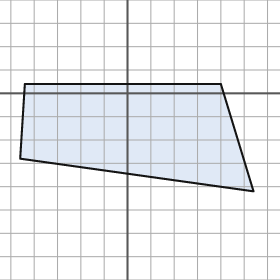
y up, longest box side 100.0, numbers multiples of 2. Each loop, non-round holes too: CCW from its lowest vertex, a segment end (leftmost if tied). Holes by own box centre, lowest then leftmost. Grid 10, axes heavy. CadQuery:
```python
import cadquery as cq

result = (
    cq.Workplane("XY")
    .moveTo(54.0, -42.0)
    .lineTo(40.0, 4.0)
    .lineTo(-44.0, 4.0)
    .lineTo(-46.0, -28.0)
    .close()
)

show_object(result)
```